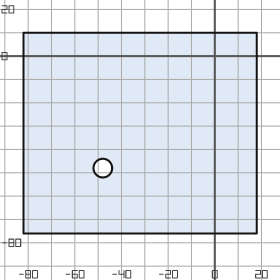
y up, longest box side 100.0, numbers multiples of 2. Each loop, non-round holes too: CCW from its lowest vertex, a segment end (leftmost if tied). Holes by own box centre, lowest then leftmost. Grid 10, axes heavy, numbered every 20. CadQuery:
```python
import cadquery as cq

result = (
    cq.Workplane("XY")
    .moveTo(-82.0, -76.0)
    .lineTo(18.0, -76.0)
    .lineTo(18.0, 10.0)
    .lineTo(-82.0, 10.0)
    .close()
    .moveTo(-48.0, -48.0)
    .circle(4.0)
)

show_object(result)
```